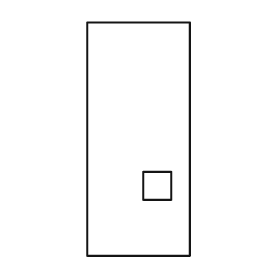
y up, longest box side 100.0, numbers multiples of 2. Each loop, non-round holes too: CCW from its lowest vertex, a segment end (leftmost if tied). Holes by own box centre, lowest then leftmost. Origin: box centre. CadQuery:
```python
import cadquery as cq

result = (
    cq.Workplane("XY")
    .moveTo(-22.0, -50.0)
    .lineTo(22.0, -50.0)
    .lineTo(22.0, 50.0)
    .lineTo(-22.0, 50.0)
    .close()
    .moveTo(2.0, -26.0)
    .lineTo(14.0, -26.0)
    .lineTo(14.0, -14.0)
    .lineTo(2.0, -14.0)
    .close()
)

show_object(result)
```